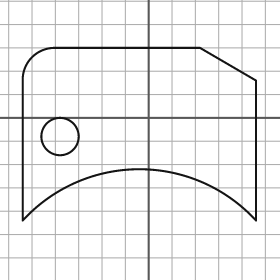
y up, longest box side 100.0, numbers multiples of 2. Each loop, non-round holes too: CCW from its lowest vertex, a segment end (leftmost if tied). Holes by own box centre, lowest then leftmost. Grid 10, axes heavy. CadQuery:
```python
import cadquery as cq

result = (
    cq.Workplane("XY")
    .moveTo(-54.0, -44.0)
    .threePointArc((-4.0, -22.0), (46.0, -44.0))
    .lineTo(46.0, 16.0)
    .lineTo(22.0, 30.0)
    .lineTo(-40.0, 30.0)
    .threePointArc((-50.0, 26.0), (-54.0, 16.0))
    .close()
    .moveTo(-38.0, -8.0)
    .circle(8.0)
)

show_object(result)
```